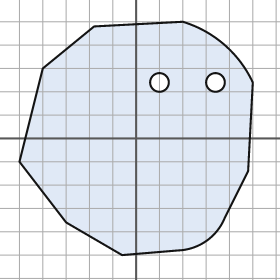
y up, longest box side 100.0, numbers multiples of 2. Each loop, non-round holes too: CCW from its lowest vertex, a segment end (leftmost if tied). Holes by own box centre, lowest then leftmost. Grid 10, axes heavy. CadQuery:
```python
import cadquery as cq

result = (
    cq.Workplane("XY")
    .moveTo(-6.0, -50.0)
    .lineTo(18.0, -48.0)
    .threePointArc((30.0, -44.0), (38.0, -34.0))
    .lineTo(48.0, -14.0)
    .lineTo(50.0, 24.0)
    .threePointArc((38.0, 40.0), (20.0, 50.0))
    .lineTo(-18.0, 48.0)
    .lineTo(-40.0, 30.0)
    .lineTo(-50.0, -10.0)
    .lineTo(-30.0, -36.0)
    .close()
    .moveTo(10.0, 24.0)
    .circle(4.0)
    .moveTo(34.0, 24.0)
    .circle(4.0)
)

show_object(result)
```